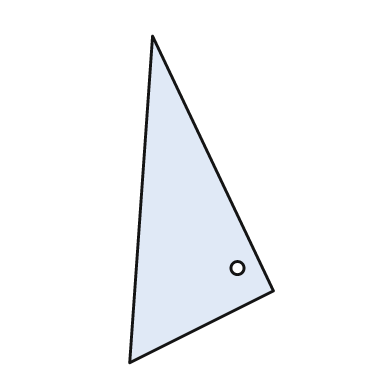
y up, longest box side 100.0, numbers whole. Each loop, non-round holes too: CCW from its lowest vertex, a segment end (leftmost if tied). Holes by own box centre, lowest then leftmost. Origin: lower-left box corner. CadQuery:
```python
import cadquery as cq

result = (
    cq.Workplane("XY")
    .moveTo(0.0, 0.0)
    .lineTo(44.0, 22.0)
    .lineTo(7.0, 100.0)
    .close()
    .moveTo(33.0, 29.0)
    .circle(2.0)
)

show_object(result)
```